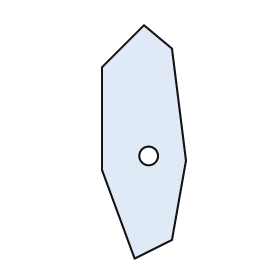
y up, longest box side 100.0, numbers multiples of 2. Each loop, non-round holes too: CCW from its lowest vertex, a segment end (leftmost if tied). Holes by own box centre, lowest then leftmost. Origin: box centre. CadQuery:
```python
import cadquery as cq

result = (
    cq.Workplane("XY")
    .moveTo(-4.0, -50.0)
    .lineTo(12.0, -42.0)
    .lineTo(18.0, -8.0)
    .lineTo(12.0, 40.0)
    .lineTo(0.0, 50.0)
    .lineTo(-18.0, 32.0)
    .lineTo(-18.0, -12.0)
    .close()
    .moveTo(2.0, -6.0)
    .circle(4.0)
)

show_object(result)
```